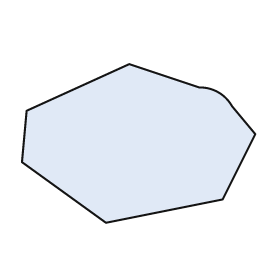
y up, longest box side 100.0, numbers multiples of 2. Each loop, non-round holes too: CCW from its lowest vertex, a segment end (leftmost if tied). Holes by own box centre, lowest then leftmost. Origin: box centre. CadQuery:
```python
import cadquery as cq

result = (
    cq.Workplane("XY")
    .moveTo(-14.0, -34.0)
    .lineTo(36.0, -24.0)
    .lineTo(50.0, 4.0)
    .lineTo(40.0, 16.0)
    .threePointArc((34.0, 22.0), (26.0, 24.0))
    .lineTo(-4.0, 34.0)
    .lineTo(-48.0, 14.0)
    .lineTo(-50.0, -8.0)
    .close()
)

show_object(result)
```